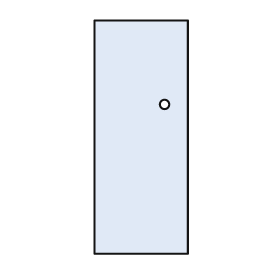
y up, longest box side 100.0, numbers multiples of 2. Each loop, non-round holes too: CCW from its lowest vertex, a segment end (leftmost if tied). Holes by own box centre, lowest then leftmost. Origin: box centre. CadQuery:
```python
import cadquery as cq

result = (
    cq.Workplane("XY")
    .moveTo(-20.0, -50.0)
    .lineTo(20.0, -50.0)
    .lineTo(20.0, 50.0)
    .lineTo(-20.0, 50.0)
    .close()
    .moveTo(10.0, 14.0)
    .circle(2.0)
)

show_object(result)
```